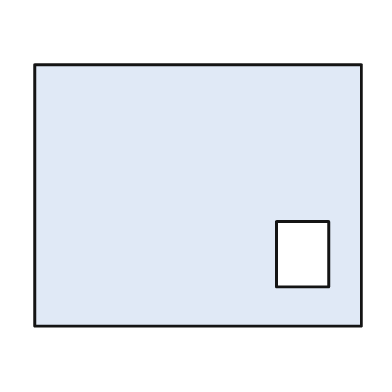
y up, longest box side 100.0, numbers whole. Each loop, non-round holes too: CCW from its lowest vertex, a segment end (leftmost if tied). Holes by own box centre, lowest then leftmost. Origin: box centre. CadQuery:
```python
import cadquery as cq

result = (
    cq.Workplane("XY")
    .moveTo(-50.0, -40.0)
    .lineTo(50.0, -40.0)
    .lineTo(50.0, 40.0)
    .lineTo(-50.0, 40.0)
    .close()
    .moveTo(24.0, -28.0)
    .lineTo(40.0, -28.0)
    .lineTo(40.0, -8.0)
    .lineTo(24.0, -8.0)
    .close()
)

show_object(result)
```